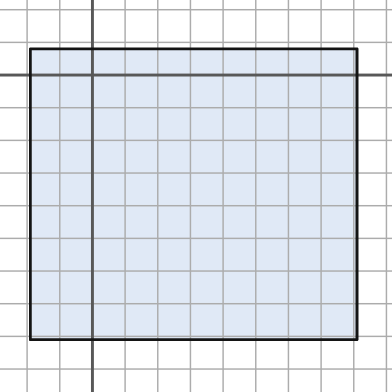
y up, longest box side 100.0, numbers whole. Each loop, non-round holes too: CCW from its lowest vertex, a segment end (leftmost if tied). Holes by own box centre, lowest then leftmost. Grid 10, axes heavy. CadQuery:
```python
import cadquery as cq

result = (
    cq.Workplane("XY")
    .moveTo(-19.0, -81.0)
    .lineTo(81.0, -81.0)
    .lineTo(81.0, 8.0)
    .lineTo(-19.0, 8.0)
    .close()
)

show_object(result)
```